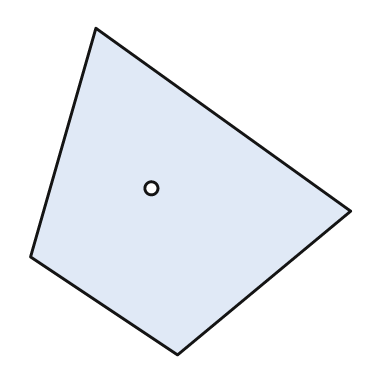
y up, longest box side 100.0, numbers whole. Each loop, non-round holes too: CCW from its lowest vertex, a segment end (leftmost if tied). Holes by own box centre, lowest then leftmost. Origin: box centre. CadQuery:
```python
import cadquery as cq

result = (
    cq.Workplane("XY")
    .moveTo(-4.0, -50.0)
    .lineTo(49.0, -6.0)
    .lineTo(-29.0, 50.0)
    .lineTo(-49.0, -20.0)
    .close()
    .moveTo(-12.0, 1.0)
    .circle(2.0)
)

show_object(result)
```